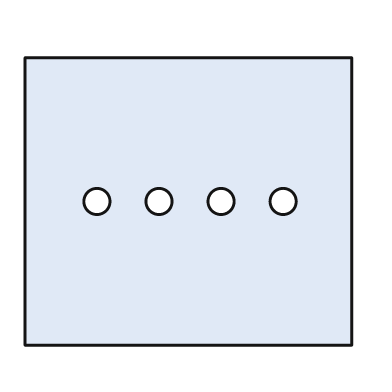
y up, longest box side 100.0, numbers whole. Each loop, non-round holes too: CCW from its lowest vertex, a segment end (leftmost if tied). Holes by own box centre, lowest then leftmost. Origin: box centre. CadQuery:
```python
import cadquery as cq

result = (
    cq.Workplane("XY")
    .moveTo(-50.0, -44.0)
    .lineTo(50.0, -44.0)
    .lineTo(50.0, 44.0)
    .lineTo(-50.0, 44.0)
    .close()
    .moveTo(-28.0, 0.0)
    .circle(4.0)
    .moveTo(-9.0, 0.0)
    .circle(4.0)
    .moveTo(10.0, 0.0)
    .circle(4.0)
    .moveTo(29.0, 0.0)
    .circle(4.0)
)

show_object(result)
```